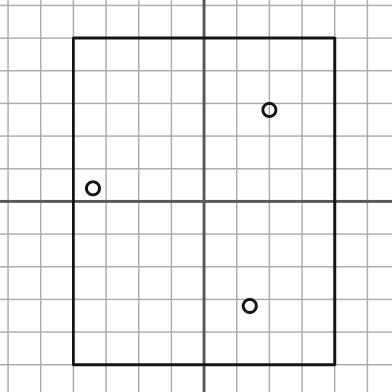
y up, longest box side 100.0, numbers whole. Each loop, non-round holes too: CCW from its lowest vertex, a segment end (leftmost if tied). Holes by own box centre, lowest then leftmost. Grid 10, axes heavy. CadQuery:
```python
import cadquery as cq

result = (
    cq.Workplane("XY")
    .moveTo(-40.0, -50.0)
    .lineTo(40.0, -50.0)
    .lineTo(40.0, 50.0)
    .lineTo(-40.0, 50.0)
    .close()
    .moveTo(14.0, -32.0)
    .circle(2.0)
    .moveTo(-34.0, 4.0)
    .circle(2.0)
    .moveTo(20.0, 28.0)
    .circle(2.0)
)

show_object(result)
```